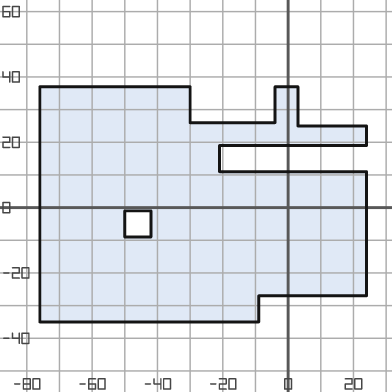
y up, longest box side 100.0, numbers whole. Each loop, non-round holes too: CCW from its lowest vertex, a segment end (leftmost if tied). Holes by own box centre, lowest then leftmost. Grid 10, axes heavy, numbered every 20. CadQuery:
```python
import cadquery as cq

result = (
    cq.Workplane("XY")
    .moveTo(-76.0, -35.0)
    .lineTo(-9.0, -35.0)
    .lineTo(-9.0, -27.0)
    .lineTo(24.0, -27.0)
    .lineTo(24.0, 11.0)
    .lineTo(-21.0, 11.0)
    .lineTo(-21.0, 19.0)
    .lineTo(24.0, 19.0)
    .lineTo(24.0, 25.0)
    .lineTo(3.0, 25.0)
    .lineTo(3.0, 37.0)
    .lineTo(-4.0, 37.0)
    .lineTo(-4.0, 26.0)
    .lineTo(-30.0, 26.0)
    .lineTo(-30.0, 37.0)
    .lineTo(-76.0, 37.0)
    .close()
    .moveTo(-50.0, -9.0)
    .lineTo(-42.0, -9.0)
    .lineTo(-42.0, -1.0)
    .lineTo(-50.0, -1.0)
    .close()
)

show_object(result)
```